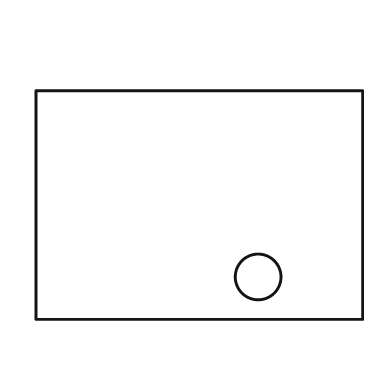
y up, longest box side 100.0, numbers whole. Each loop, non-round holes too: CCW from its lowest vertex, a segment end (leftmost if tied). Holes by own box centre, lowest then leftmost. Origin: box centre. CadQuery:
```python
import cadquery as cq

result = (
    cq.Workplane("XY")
    .moveTo(-50.0, -35.0)
    .lineTo(50.0, -35.0)
    .lineTo(50.0, 35.0)
    .lineTo(-50.0, 35.0)
    .close()
    .moveTo(18.0, -22.0)
    .circle(7.0)
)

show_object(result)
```